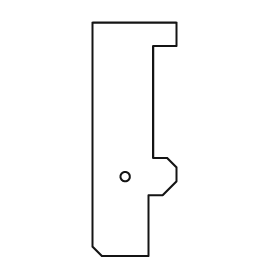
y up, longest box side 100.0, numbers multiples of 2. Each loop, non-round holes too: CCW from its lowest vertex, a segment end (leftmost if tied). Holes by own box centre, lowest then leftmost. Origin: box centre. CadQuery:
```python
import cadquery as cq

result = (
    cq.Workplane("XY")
    .moveTo(-14.0, -50.0)
    .lineTo(6.0, -50.0)
    .lineTo(6.0, -24.0)
    .lineTo(12.0, -24.0)
    .lineTo(18.0, -18.0)
    .lineTo(18.0, -12.0)
    .lineTo(14.0, -8.0)
    .lineTo(8.0, -8.0)
    .lineTo(8.0, 40.0)
    .lineTo(18.0, 40.0)
    .lineTo(18.0, 50.0)
    .lineTo(-18.0, 50.0)
    .lineTo(-18.0, -46.0)
    .close()
    .moveTo(-4.0, -16.0)
    .circle(2.0)
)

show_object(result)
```